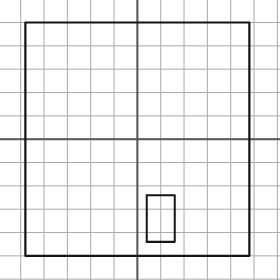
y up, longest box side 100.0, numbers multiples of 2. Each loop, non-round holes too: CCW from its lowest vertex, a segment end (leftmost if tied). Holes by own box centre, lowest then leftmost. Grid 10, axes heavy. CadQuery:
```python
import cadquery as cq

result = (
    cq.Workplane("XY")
    .moveTo(-48.0, -50.0)
    .lineTo(48.0, -50.0)
    .lineTo(48.0, 50.0)
    .lineTo(-48.0, 50.0)
    .close()
    .moveTo(4.0, -44.0)
    .lineTo(16.0, -44.0)
    .lineTo(16.0, -24.0)
    .lineTo(4.0, -24.0)
    .close()
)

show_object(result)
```